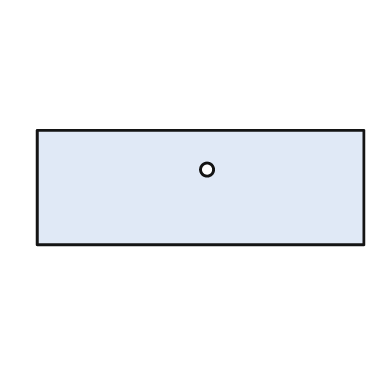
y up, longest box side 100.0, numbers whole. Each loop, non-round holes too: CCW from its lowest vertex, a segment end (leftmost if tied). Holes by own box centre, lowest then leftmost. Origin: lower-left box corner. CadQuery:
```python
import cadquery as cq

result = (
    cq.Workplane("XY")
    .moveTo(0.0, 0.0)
    .lineTo(100.0, 0.0)
    .lineTo(100.0, 35.0)
    .lineTo(0.0, 35.0)
    .close()
    .moveTo(52.0, 23.0)
    .circle(2.0)
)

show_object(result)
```